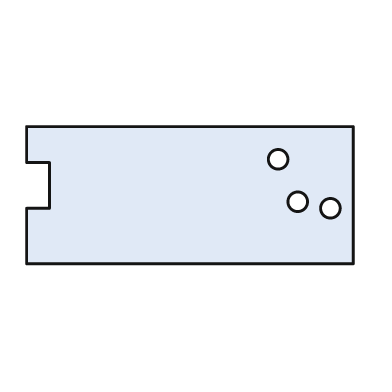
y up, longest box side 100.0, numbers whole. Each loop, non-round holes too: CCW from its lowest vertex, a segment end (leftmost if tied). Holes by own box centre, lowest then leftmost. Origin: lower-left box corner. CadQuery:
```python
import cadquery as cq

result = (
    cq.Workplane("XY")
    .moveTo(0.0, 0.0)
    .lineTo(100.0, 0.0)
    .lineTo(100.0, 42.0)
    .lineTo(0.0, 42.0)
    .lineTo(0.0, 31.0)
    .lineTo(7.0, 31.0)
    .lineTo(7.0, 17.0)
    .lineTo(0.0, 17.0)
    .close()
    .moveTo(93.0, 17.0)
    .circle(3.0)
    .moveTo(83.0, 19.0)
    .circle(3.0)
    .moveTo(77.0, 32.0)
    .circle(3.0)
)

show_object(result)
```